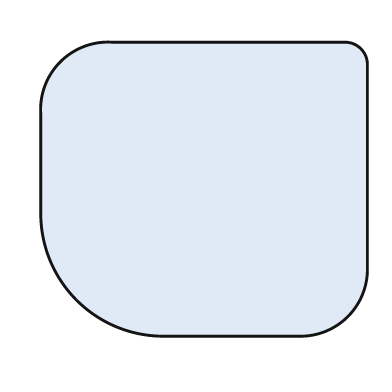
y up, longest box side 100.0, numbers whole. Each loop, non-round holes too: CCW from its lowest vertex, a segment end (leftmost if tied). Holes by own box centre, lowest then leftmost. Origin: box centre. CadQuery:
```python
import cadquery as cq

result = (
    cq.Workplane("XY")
    .moveTo(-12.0, -45.0)
    .lineTo(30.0, -45.0)
    .threePointArc((44.0, -39.0), (50.0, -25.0))
    .lineTo(50.0, 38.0)
    .threePointArc((48.0, 43.0), (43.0, 45.0))
    .lineTo(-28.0, 45.0)
    .threePointArc((-44.0, 39.0), (-50.0, 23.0))
    .lineTo(-50.0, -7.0)
    .threePointArc((-39.0, -34.0), (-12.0, -45.0))
    .close()
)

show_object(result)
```